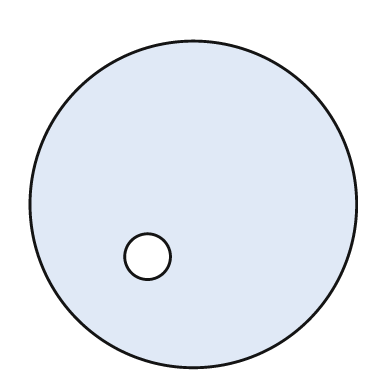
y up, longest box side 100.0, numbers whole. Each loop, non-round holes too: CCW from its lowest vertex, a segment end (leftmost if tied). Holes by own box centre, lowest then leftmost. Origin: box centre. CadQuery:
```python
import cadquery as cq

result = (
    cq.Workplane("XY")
    .moveTo(0.0, 0.0)
    .circle(50.0)
    .moveTo(-14.0, -16.0)
    .circle(7.0)
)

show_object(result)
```